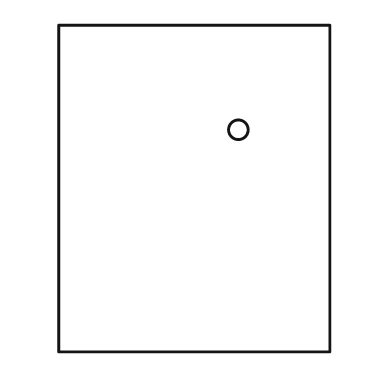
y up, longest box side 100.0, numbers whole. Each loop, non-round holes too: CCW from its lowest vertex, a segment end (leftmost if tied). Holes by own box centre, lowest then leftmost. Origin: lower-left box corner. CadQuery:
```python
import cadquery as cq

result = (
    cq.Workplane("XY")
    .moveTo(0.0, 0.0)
    .lineTo(83.0, 0.0)
    .lineTo(83.0, 100.0)
    .lineTo(0.0, 100.0)
    .close()
    .moveTo(55.0, 68.0)
    .circle(3.0)
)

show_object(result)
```